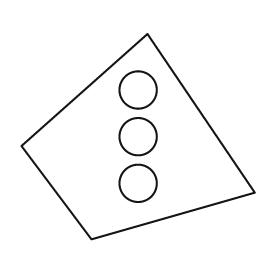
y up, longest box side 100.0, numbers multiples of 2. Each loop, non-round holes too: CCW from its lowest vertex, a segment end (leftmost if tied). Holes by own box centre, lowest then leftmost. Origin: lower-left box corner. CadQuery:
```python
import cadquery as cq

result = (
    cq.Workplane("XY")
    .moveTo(30.0, 0.0)
    .lineTo(100.0, 20.0)
    .lineTo(54.0, 88.0)
    .lineTo(0.0, 40.0)
    .close()
    .moveTo(50.0, 24.0)
    .circle(8.0)
    .moveTo(50.0, 44.0)
    .circle(8.0)
    .moveTo(50.0, 64.0)
    .circle(8.0)
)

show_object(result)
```